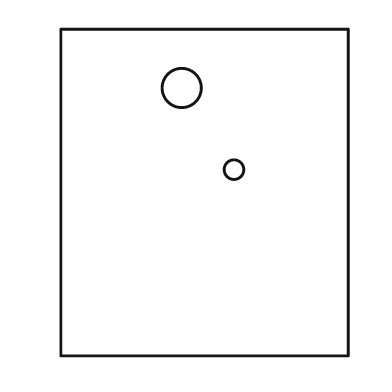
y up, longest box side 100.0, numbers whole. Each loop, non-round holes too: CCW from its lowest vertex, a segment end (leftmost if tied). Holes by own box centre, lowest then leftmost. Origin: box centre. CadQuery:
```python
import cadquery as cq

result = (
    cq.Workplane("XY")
    .moveTo(-44.0, -50.0)
    .lineTo(44.0, -50.0)
    .lineTo(44.0, 50.0)
    .lineTo(-44.0, 50.0)
    .close()
    .moveTo(9.0, 7.0)
    .circle(3.0)
    .moveTo(-7.0, 32.0)
    .circle(6.0)
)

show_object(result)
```